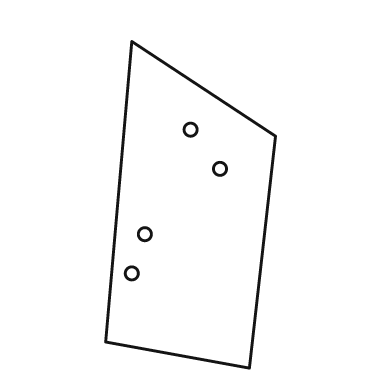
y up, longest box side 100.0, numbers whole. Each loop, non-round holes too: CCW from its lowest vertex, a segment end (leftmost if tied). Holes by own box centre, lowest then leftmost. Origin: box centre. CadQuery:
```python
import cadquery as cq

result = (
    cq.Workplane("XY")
    .moveTo(18.0, -50.0)
    .lineTo(26.0, 21.0)
    .lineTo(-18.0, 50.0)
    .lineTo(-26.0, -42.0)
    .close()
    .moveTo(-18.0, -21.0)
    .circle(2.0)
    .moveTo(-14.0, -9.0)
    .circle(2.0)
    .moveTo(9.0, 11.0)
    .circle(2.0)
    .moveTo(0.0, 23.0)
    .circle(2.0)
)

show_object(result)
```